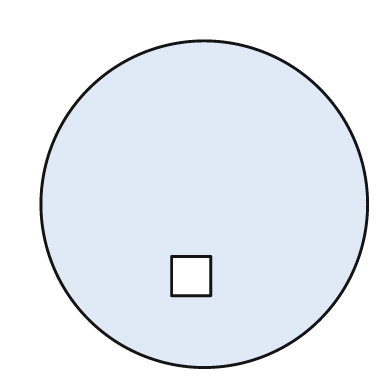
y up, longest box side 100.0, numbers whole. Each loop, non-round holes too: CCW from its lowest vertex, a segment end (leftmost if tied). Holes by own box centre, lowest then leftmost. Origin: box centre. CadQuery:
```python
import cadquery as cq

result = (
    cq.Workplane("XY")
    .moveTo(0.0, 0.0)
    .circle(50.0)
    .moveTo(-10.0, -28.0)
    .lineTo(2.0, -28.0)
    .lineTo(2.0, -16.0)
    .lineTo(-10.0, -16.0)
    .close()
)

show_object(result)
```